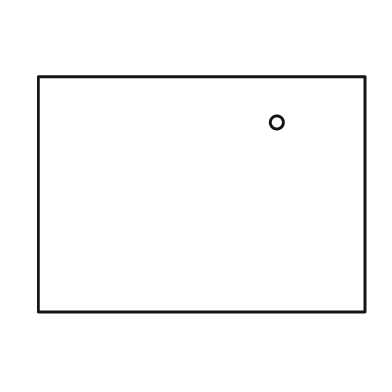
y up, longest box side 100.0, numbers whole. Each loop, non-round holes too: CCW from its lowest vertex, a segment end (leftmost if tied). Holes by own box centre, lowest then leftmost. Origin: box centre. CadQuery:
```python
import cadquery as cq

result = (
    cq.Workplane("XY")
    .moveTo(-50.0, -36.0)
    .lineTo(50.0, -36.0)
    .lineTo(50.0, 36.0)
    .lineTo(-50.0, 36.0)
    .close()
    .moveTo(23.0, 22.0)
    .circle(2.0)
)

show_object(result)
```